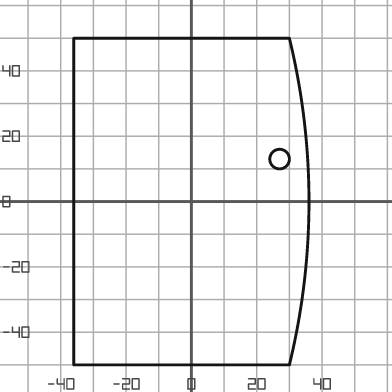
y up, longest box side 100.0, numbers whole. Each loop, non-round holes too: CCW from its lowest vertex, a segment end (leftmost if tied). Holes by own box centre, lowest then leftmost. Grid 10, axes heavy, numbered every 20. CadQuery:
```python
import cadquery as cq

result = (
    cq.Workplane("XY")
    .moveTo(-36.0, -50.0)
    .lineTo(30.0, -50.0)
    .threePointArc((36.0, 0.0), (30.0, 50.0))
    .lineTo(-36.0, 50.0)
    .close()
    .moveTo(27.0, 13.0)
    .circle(3.0)
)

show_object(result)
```